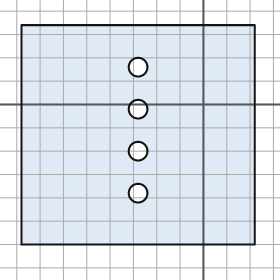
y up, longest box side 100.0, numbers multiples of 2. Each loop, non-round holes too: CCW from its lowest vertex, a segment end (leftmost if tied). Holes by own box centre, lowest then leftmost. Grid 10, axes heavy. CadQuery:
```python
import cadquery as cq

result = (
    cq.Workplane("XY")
    .moveTo(-78.0, -60.0)
    .lineTo(22.0, -60.0)
    .lineTo(22.0, 34.0)
    .lineTo(-78.0, 34.0)
    .close()
    .moveTo(-28.0, -38.0)
    .circle(4.0)
    .moveTo(-28.0, -20.0)
    .circle(4.0)
    .moveTo(-28.0, -2.0)
    .circle(4.0)
    .moveTo(-28.0, 16.0)
    .circle(4.0)
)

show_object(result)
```